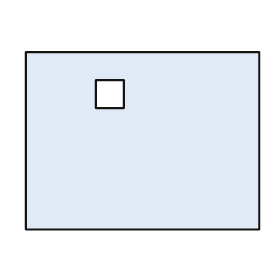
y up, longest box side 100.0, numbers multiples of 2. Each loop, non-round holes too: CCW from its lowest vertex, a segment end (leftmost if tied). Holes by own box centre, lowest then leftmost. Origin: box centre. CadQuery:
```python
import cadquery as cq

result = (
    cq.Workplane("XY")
    .moveTo(-50.0, -38.0)
    .lineTo(50.0, -38.0)
    .lineTo(50.0, 38.0)
    .lineTo(-50.0, 38.0)
    .close()
    .moveTo(-20.0, 14.0)
    .lineTo(-8.0, 14.0)
    .lineTo(-8.0, 26.0)
    .lineTo(-20.0, 26.0)
    .close()
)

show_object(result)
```